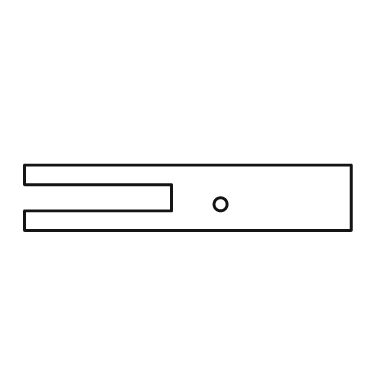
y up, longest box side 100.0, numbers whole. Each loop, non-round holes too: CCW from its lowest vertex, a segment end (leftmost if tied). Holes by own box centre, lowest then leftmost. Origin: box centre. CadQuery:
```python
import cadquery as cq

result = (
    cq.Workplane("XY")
    .moveTo(-50.0, -10.0)
    .lineTo(50.0, -10.0)
    .lineTo(50.0, 10.0)
    .lineTo(-50.0, 10.0)
    .lineTo(-50.0, 4.0)
    .lineTo(-5.0, 4.0)
    .lineTo(-5.0, -4.0)
    .lineTo(-50.0, -4.0)
    .close()
    .moveTo(10.0, -2.0)
    .circle(2.0)
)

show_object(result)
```